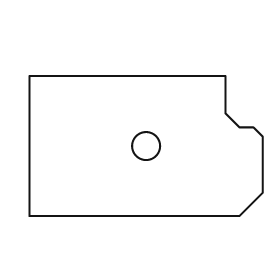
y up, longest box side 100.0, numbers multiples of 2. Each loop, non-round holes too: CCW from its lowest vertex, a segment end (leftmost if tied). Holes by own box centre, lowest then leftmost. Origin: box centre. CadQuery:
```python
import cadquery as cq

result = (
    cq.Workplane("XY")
    .moveTo(-50.0, -30.0)
    .lineTo(40.0, -30.0)
    .lineTo(50.0, -20.0)
    .lineTo(50.0, 4.0)
    .lineTo(46.0, 8.0)
    .lineTo(40.0, 8.0)
    .lineTo(34.0, 14.0)
    .lineTo(34.0, 30.0)
    .lineTo(-50.0, 30.0)
    .close()
    .moveTo(0.0, 0.0)
    .circle(6.0)
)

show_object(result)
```